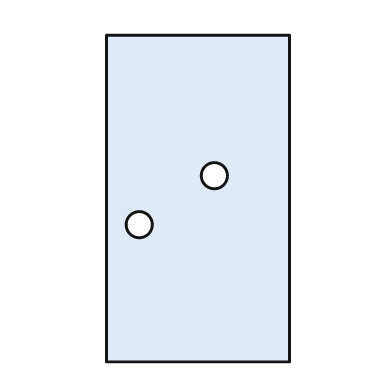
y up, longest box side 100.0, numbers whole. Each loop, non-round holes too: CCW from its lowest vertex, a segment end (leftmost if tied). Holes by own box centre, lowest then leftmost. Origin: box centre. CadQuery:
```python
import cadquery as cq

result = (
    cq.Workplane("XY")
    .moveTo(-28.0, -50.0)
    .lineTo(28.0, -50.0)
    .lineTo(28.0, 50.0)
    .lineTo(-28.0, 50.0)
    .close()
    .moveTo(-18.0, -8.0)
    .circle(4.0)
    .moveTo(5.0, 7.0)
    .circle(4.0)
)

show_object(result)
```